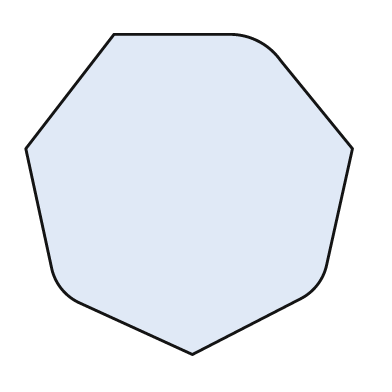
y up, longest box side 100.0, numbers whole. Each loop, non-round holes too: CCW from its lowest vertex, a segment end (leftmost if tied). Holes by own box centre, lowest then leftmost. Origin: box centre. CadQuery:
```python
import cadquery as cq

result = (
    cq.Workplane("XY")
    .moveTo(1.0, -49.0)
    .lineTo(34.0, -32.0)
    .threePointArc((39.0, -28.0), (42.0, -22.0))
    .lineTo(50.0, 14.0)
    .lineTo(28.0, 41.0)
    .threePointArc((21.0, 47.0), (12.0, 49.0))
    .lineTo(-23.0, 49.0)
    .lineTo(-50.0, 14.0)
    .lineTo(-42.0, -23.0)
    .threePointArc((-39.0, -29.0), (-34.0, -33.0))
    .close()
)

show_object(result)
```